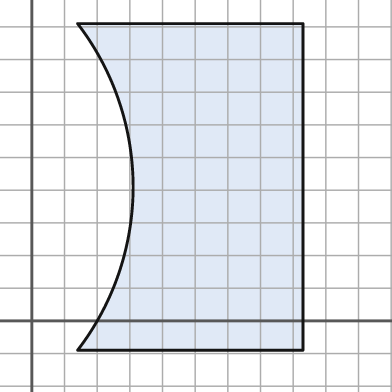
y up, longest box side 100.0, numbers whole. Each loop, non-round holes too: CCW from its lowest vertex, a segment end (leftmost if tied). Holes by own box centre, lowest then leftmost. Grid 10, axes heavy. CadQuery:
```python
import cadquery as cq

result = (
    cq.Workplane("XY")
    .moveTo(14.0, -9.0)
    .lineTo(83.0, -9.0)
    .lineTo(83.0, 91.0)
    .lineTo(14.0, 91.0)
    .threePointArc((31.0, 41.0), (14.0, -9.0))
    .close()
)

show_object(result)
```